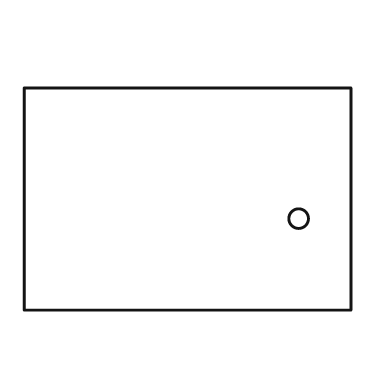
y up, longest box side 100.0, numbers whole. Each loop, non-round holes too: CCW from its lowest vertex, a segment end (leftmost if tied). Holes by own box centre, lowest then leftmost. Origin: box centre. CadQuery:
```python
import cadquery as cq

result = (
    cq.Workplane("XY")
    .moveTo(-50.0, -34.0)
    .lineTo(50.0, -34.0)
    .lineTo(50.0, 34.0)
    .lineTo(-50.0, 34.0)
    .close()
    .moveTo(34.0, -6.0)
    .circle(3.0)
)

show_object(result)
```